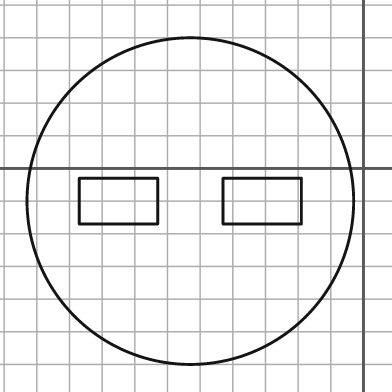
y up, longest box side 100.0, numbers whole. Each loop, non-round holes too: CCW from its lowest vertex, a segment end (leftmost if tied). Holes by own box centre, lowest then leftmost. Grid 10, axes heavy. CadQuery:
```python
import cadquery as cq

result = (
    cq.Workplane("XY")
    .moveTo(-53.0, -10.0)
    .circle(50.0)
    .moveTo(-87.0, -17.0)
    .lineTo(-63.0, -17.0)
    .lineTo(-63.0, -3.0)
    .lineTo(-87.0, -3.0)
    .close()
    .moveTo(-43.0, -17.0)
    .lineTo(-19.0, -17.0)
    .lineTo(-19.0, -3.0)
    .lineTo(-43.0, -3.0)
    .close()
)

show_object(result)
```